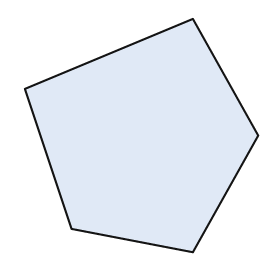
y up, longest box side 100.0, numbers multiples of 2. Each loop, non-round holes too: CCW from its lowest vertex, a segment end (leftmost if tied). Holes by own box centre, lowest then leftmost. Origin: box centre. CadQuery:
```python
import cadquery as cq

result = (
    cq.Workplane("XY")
    .moveTo(22.0, -50.0)
    .lineTo(50.0, 0.0)
    .lineTo(22.0, 50.0)
    .lineTo(-50.0, 20.0)
    .lineTo(-30.0, -40.0)
    .close()
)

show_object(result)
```